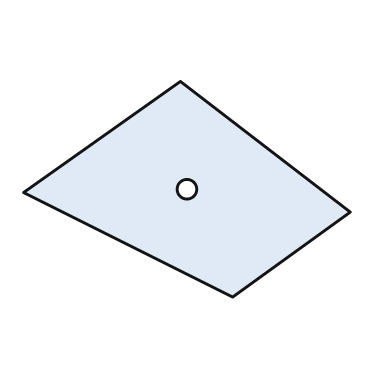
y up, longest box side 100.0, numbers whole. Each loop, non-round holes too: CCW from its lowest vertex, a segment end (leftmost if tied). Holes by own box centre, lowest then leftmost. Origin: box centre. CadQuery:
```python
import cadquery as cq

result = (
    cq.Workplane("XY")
    .moveTo(14.0, -33.0)
    .lineTo(50.0, -7.0)
    .lineTo(-2.0, 33.0)
    .lineTo(-50.0, -1.0)
    .close()
    .moveTo(0.0, 0.0)
    .circle(3.0)
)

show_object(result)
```